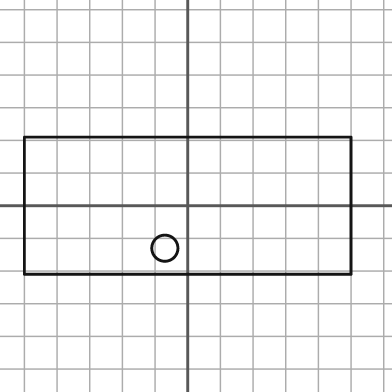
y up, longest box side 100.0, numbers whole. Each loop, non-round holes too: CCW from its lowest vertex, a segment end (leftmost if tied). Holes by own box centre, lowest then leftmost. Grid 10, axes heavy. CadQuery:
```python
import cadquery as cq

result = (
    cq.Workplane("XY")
    .moveTo(-50.0, -21.0)
    .lineTo(50.0, -21.0)
    .lineTo(50.0, 21.0)
    .lineTo(-50.0, 21.0)
    .close()
    .moveTo(-7.0, -13.0)
    .circle(4.0)
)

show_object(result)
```